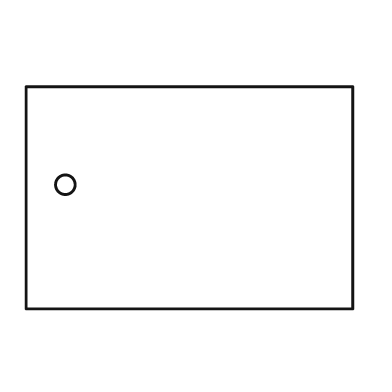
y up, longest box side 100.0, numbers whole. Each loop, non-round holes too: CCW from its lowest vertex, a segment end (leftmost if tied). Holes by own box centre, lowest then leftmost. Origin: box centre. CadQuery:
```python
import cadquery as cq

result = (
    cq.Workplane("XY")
    .moveTo(-50.0, -34.0)
    .lineTo(50.0, -34.0)
    .lineTo(50.0, 34.0)
    .lineTo(-50.0, 34.0)
    .close()
    .moveTo(-38.0, 4.0)
    .circle(3.0)
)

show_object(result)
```